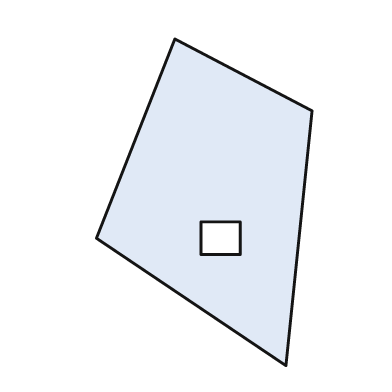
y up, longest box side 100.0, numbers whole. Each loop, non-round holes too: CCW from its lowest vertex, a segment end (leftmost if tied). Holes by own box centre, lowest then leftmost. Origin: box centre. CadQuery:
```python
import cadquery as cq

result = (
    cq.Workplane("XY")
    .moveTo(25.0, -50.0)
    .lineTo(33.0, 28.0)
    .lineTo(-9.0, 50.0)
    .lineTo(-33.0, -11.0)
    .close()
    .moveTo(-1.0, -16.0)
    .lineTo(11.0, -16.0)
    .lineTo(11.0, -6.0)
    .lineTo(-1.0, -6.0)
    .close()
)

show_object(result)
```